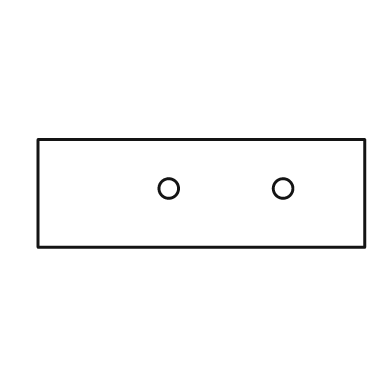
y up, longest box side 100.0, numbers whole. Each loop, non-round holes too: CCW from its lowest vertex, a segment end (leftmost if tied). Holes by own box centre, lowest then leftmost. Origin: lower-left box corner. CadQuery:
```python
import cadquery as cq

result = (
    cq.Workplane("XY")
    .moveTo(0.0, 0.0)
    .lineTo(100.0, 0.0)
    .lineTo(100.0, 33.0)
    .lineTo(0.0, 33.0)
    .close()
    .moveTo(40.0, 18.0)
    .circle(3.0)
    .moveTo(75.0, 18.0)
    .circle(3.0)
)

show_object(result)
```